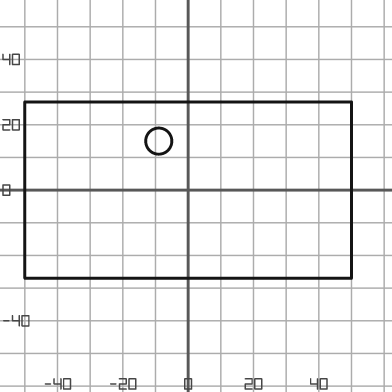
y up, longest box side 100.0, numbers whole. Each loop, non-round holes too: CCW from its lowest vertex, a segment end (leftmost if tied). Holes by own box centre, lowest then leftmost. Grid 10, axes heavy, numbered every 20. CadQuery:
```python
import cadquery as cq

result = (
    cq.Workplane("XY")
    .moveTo(-50.0, -27.0)
    .lineTo(50.0, -27.0)
    .lineTo(50.0, 27.0)
    .lineTo(-50.0, 27.0)
    .close()
    .moveTo(-9.0, 15.0)
    .circle(4.0)
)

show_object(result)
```